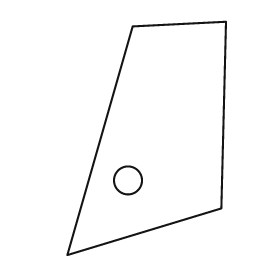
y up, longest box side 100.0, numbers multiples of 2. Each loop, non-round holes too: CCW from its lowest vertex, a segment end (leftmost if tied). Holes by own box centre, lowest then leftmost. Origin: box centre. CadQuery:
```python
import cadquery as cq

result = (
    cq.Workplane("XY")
    .moveTo(-34.0, -50.0)
    .lineTo(32.0, -30.0)
    .lineTo(34.0, 50.0)
    .lineTo(-6.0, 48.0)
    .close()
    .moveTo(-8.0, -18.0)
    .circle(6.0)
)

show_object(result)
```